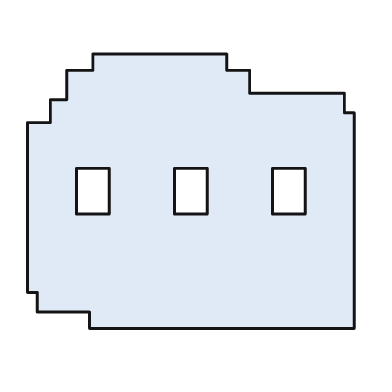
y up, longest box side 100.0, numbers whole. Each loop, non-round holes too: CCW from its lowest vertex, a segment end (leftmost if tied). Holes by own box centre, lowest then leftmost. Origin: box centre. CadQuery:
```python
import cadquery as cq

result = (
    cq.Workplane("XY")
    .moveTo(-31.0, -42.0)
    .lineTo(50.0, -42.0)
    .lineTo(50.0, 24.0)
    .lineTo(47.0, 24.0)
    .lineTo(47.0, 30.0)
    .lineTo(18.0, 30.0)
    .lineTo(18.0, 37.0)
    .lineTo(11.0, 37.0)
    .lineTo(11.0, 42.0)
    .lineTo(-30.0, 42.0)
    .lineTo(-30.0, 37.0)
    .lineTo(-38.0, 37.0)
    .lineTo(-38.0, 28.0)
    .lineTo(-43.0, 28.0)
    .lineTo(-43.0, 21.0)
    .lineTo(-50.0, 21.0)
    .lineTo(-50.0, -31.0)
    .lineTo(-47.0, -31.0)
    .lineTo(-47.0, -37.0)
    .lineTo(-31.0, -37.0)
    .close()
    .moveTo(-35.0, -7.0)
    .lineTo(-25.0, -7.0)
    .lineTo(-25.0, 7.0)
    .lineTo(-35.0, 7.0)
    .close()
    .moveTo(-5.0, -7.0)
    .lineTo(5.0, -7.0)
    .lineTo(5.0, 7.0)
    .lineTo(-5.0, 7.0)
    .close()
    .moveTo(25.0, -7.0)
    .lineTo(35.0, -7.0)
    .lineTo(35.0, 7.0)
    .lineTo(25.0, 7.0)
    .close()
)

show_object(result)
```